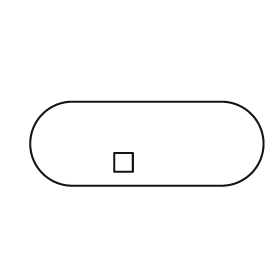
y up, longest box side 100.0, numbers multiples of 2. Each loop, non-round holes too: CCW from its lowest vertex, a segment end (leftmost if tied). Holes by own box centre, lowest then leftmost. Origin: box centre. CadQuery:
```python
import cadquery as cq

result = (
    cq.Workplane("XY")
    .moveTo(-32.0, -18.0)
    .lineTo(32.0, -18.0)
    .threePointArc((50.0, 0.0), (32.0, 18.0))
    .lineTo(-32.0, 18.0)
    .threePointArc((-50.0, 0.0), (-32.0, -18.0))
    .close()
    .moveTo(-14.0, -12.0)
    .lineTo(-6.0, -12.0)
    .lineTo(-6.0, -4.0)
    .lineTo(-14.0, -4.0)
    .close()
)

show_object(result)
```